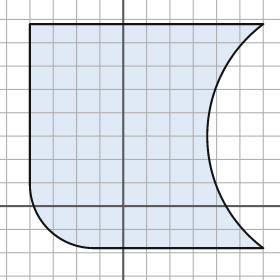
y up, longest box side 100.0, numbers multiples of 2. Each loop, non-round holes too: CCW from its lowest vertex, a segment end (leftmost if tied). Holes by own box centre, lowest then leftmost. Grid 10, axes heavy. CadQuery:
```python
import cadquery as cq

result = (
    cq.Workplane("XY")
    .moveTo(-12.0, -18.0)
    .lineTo(60.0, -18.0)
    .threePointArc((36.0, 30.0), (60.0, 78.0))
    .lineTo(-40.0, 78.0)
    .lineTo(-40.0, 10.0)
    .threePointArc((-32.0, -10.0), (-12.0, -18.0))
    .close()
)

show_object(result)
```